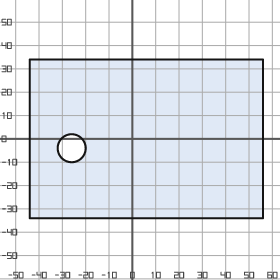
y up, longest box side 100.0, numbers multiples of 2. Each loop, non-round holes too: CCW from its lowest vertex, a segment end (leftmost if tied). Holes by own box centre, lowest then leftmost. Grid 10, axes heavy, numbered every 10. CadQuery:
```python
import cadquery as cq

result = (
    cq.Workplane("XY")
    .moveTo(-44.0, -34.0)
    .lineTo(56.0, -34.0)
    .lineTo(56.0, 34.0)
    .lineTo(-44.0, 34.0)
    .close()
    .moveTo(-26.0, -4.0)
    .circle(6.0)
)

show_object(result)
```